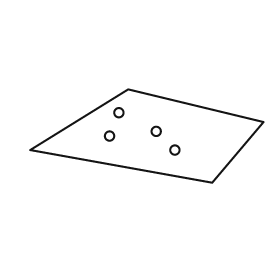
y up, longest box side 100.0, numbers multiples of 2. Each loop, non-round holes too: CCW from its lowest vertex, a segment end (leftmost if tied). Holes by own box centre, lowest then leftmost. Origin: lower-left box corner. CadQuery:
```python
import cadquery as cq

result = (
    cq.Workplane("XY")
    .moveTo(78.0, 0.0)
    .lineTo(100.0, 26.0)
    .lineTo(42.0, 40.0)
    .lineTo(0.0, 14.0)
    .close()
    .moveTo(62.0, 14.0)
    .circle(2.0)
    .moveTo(34.0, 20.0)
    .circle(2.0)
    .moveTo(54.0, 22.0)
    .circle(2.0)
    .moveTo(38.0, 30.0)
    .circle(2.0)
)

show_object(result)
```